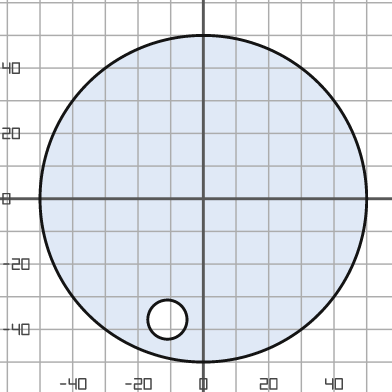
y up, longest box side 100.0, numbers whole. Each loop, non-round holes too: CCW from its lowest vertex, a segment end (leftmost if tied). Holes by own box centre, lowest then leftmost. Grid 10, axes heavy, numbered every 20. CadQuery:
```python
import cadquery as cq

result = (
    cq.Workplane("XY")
    .moveTo(0.0, 0.0)
    .circle(50.0)
    .moveTo(-11.0, -37.0)
    .circle(6.0)
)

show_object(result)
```